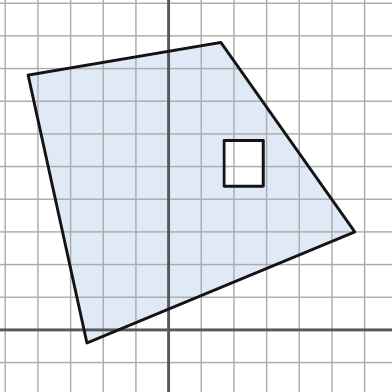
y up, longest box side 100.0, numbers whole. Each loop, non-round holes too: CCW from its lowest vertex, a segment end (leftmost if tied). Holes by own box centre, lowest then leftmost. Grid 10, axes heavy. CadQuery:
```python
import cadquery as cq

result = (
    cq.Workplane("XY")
    .moveTo(-25.0, -4.0)
    .lineTo(57.0, 30.0)
    .lineTo(16.0, 88.0)
    .lineTo(-43.0, 78.0)
    .close()
    .moveTo(17.0, 44.0)
    .lineTo(29.0, 44.0)
    .lineTo(29.0, 58.0)
    .lineTo(17.0, 58.0)
    .close()
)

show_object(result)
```